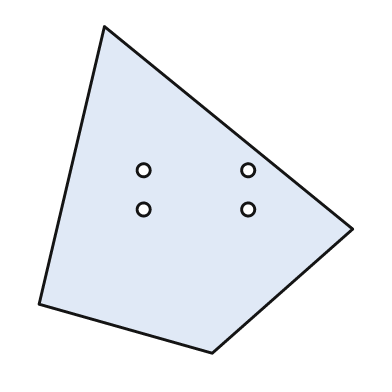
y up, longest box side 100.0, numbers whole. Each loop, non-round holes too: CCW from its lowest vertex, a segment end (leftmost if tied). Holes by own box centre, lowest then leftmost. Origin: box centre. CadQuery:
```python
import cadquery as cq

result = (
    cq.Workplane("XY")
    .moveTo(5.0, -50.0)
    .lineTo(48.0, -12.0)
    .lineTo(-28.0, 50.0)
    .lineTo(-48.0, -35.0)
    .close()
    .moveTo(-16.0, -6.0)
    .circle(2.0)
    .moveTo(16.0, -6.0)
    .circle(2.0)
    .moveTo(-16.0, 6.0)
    .circle(2.0)
    .moveTo(16.0, 6.0)
    .circle(2.0)
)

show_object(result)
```